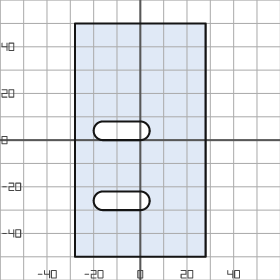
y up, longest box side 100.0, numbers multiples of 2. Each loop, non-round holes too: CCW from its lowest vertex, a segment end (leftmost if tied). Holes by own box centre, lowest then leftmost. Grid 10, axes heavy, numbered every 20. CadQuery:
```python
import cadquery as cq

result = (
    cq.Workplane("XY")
    .moveTo(-28.0, -50.0)
    .lineTo(28.0, -50.0)
    .lineTo(28.0, 50.0)
    .lineTo(-28.0, 50.0)
    .close()
    .moveTo(-16.0, -30.0)
    .lineTo(0.0, -30.0)
    .threePointArc((4.0, -26.0), (0.0, -22.0))
    .lineTo(-16.0, -22.0)
    .threePointArc((-20.0, -26.0), (-16.0, -30.0))
    .close()
    .moveTo(-16.0, 0.0)
    .lineTo(0.0, 0.0)
    .threePointArc((4.0, 4.0), (0.0, 8.0))
    .lineTo(-16.0, 8.0)
    .threePointArc((-20.0, 4.0), (-16.0, 0.0))
    .close()
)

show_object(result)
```